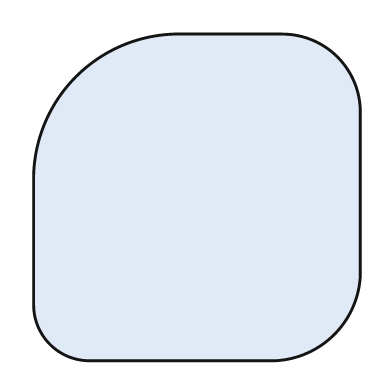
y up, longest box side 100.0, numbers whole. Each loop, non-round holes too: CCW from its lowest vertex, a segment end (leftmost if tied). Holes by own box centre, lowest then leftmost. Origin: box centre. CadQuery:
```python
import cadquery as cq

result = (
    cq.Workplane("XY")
    .moveTo(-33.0, -50.0)
    .lineTo(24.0, -50.0)
    .threePointArc((42.0, -42.0), (50.0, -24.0))
    .lineTo(50.0, 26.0)
    .threePointArc((43.0, 43.0), (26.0, 50.0))
    .lineTo(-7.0, 50.0)
    .threePointArc((-37.0, 37.0), (-50.0, 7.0))
    .lineTo(-50.0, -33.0)
    .threePointArc((-45.0, -45.0), (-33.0, -50.0))
    .close()
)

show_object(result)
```